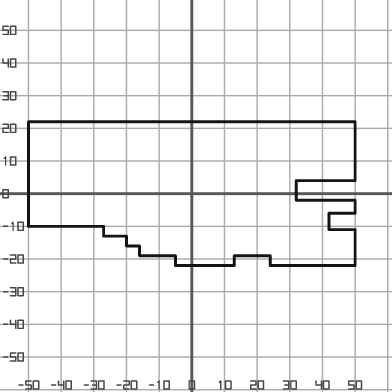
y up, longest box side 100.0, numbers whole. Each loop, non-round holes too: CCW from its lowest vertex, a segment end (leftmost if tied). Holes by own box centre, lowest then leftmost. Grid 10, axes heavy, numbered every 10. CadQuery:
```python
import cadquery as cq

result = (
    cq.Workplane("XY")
    .moveTo(-5.0, -22.0)
    .lineTo(13.0, -22.0)
    .lineTo(13.0, -19.0)
    .lineTo(24.0, -19.0)
    .lineTo(24.0, -22.0)
    .lineTo(50.0, -22.0)
    .lineTo(50.0, -11.0)
    .lineTo(42.0, -11.0)
    .lineTo(42.0, -6.0)
    .lineTo(50.0, -6.0)
    .lineTo(50.0, -2.0)
    .lineTo(32.0, -2.0)
    .lineTo(32.0, 4.0)
    .lineTo(50.0, 4.0)
    .lineTo(50.0, 22.0)
    .lineTo(-50.0, 22.0)
    .lineTo(-50.0, -10.0)
    .lineTo(-27.0, -10.0)
    .lineTo(-27.0, -13.0)
    .lineTo(-20.0, -13.0)
    .lineTo(-20.0, -16.0)
    .lineTo(-16.0, -16.0)
    .lineTo(-16.0, -19.0)
    .lineTo(-5.0, -19.0)
    .close()
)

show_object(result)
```